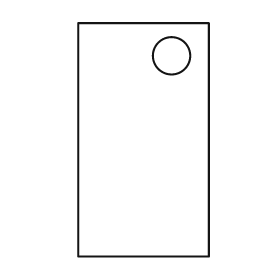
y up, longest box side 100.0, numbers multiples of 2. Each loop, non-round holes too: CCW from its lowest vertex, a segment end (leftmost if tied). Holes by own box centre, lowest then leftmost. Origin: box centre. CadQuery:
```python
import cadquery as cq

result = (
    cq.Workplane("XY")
    .moveTo(-28.0, -50.0)
    .lineTo(28.0, -50.0)
    .lineTo(28.0, 50.0)
    .lineTo(-28.0, 50.0)
    .close()
    .moveTo(12.0, 36.0)
    .circle(8.0)
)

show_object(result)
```